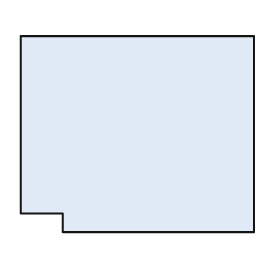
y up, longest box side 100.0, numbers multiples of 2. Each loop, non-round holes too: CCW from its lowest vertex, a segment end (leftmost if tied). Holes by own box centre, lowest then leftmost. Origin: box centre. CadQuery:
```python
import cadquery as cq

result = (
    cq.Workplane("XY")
    .moveTo(-32.0, -42.0)
    .lineTo(50.0, -42.0)
    .lineTo(50.0, 42.0)
    .lineTo(-50.0, 42.0)
    .lineTo(-50.0, -34.0)
    .lineTo(-32.0, -34.0)
    .close()
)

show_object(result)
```